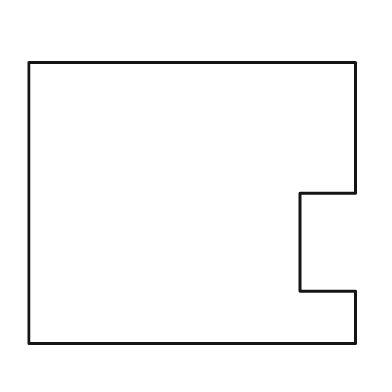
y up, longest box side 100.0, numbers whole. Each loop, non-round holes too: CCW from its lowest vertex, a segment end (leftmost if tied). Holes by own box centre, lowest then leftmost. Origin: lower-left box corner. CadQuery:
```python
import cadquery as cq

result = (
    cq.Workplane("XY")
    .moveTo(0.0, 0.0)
    .lineTo(100.0, 0.0)
    .lineTo(100.0, 16.0)
    .lineTo(83.0, 16.0)
    .lineTo(83.0, 46.0)
    .lineTo(100.0, 46.0)
    .lineTo(100.0, 86.0)
    .lineTo(0.0, 86.0)
    .close()
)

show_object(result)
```